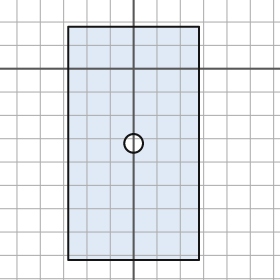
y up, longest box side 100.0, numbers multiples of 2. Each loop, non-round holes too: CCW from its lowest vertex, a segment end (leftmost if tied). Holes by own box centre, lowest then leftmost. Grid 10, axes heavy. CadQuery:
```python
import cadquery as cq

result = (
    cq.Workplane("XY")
    .moveTo(-28.0, -82.0)
    .lineTo(28.0, -82.0)
    .lineTo(28.0, 18.0)
    .lineTo(-28.0, 18.0)
    .close()
    .moveTo(0.0, -32.0)
    .circle(4.0)
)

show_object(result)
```